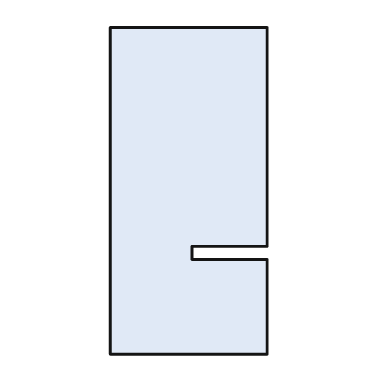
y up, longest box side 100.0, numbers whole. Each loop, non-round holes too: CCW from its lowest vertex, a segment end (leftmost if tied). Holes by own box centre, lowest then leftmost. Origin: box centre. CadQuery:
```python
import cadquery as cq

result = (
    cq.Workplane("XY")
    .moveTo(-24.0, -50.0)
    .lineTo(24.0, -50.0)
    .lineTo(24.0, -21.0)
    .lineTo(1.0, -21.0)
    .lineTo(1.0, -17.0)
    .lineTo(24.0, -17.0)
    .lineTo(24.0, 50.0)
    .lineTo(-24.0, 50.0)
    .close()
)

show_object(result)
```